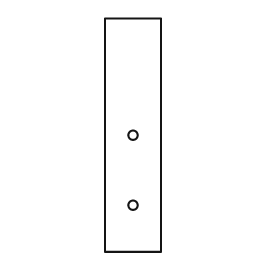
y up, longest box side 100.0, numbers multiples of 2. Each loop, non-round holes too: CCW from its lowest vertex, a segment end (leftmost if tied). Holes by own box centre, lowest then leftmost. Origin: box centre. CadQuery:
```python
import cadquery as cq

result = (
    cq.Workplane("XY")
    .moveTo(-12.0, -50.0)
    .lineTo(12.0, -50.0)
    .lineTo(12.0, 50.0)
    .lineTo(-12.0, 50.0)
    .close()
    .moveTo(0.0, -30.0)
    .circle(2.0)
    .moveTo(0.0, 0.0)
    .circle(2.0)
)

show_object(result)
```